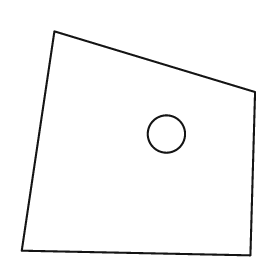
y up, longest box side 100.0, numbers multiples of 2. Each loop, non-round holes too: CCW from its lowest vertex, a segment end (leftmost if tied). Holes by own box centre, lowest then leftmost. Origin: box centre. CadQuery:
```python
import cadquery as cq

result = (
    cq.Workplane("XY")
    .moveTo(48.0, -48.0)
    .lineTo(50.0, 22.0)
    .lineTo(-36.0, 48.0)
    .lineTo(-50.0, -46.0)
    .close()
    .moveTo(12.0, 4.0)
    .circle(8.0)
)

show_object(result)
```